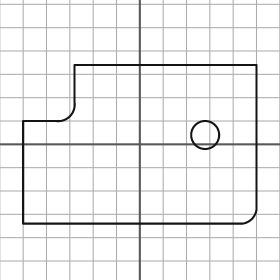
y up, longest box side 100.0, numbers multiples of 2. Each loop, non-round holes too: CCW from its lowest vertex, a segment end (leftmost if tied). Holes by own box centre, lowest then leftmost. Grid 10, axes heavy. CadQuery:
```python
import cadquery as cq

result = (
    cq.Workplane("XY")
    .moveTo(-50.0, -34.0)
    .lineTo(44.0, -34.0)
    .threePointArc((48.0, -32.0), (50.0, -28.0))
    .lineTo(50.0, 34.0)
    .lineTo(-28.0, 34.0)
    .lineTo(-28.0, 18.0)
    .threePointArc((-30.0, 12.0), (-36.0, 10.0))
    .lineTo(-50.0, 10.0)
    .close()
    .moveTo(28.0, 4.0)
    .circle(6.0)
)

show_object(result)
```